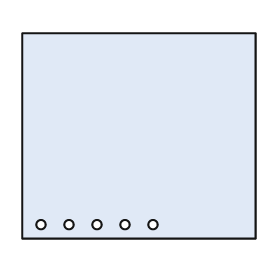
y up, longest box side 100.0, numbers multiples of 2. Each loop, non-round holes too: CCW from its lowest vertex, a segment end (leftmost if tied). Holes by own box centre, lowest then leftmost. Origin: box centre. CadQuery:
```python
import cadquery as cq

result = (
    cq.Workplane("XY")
    .moveTo(-50.0, -44.0)
    .lineTo(50.0, -44.0)
    .lineTo(50.0, 44.0)
    .lineTo(-50.0, 44.0)
    .close()
    .moveTo(-42.0, -38.0)
    .circle(2.0)
    .moveTo(-30.0, -38.0)
    .circle(2.0)
    .moveTo(-18.0, -38.0)
    .circle(2.0)
    .moveTo(-6.0, -38.0)
    .circle(2.0)
    .moveTo(6.0, -38.0)
    .circle(2.0)
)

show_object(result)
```